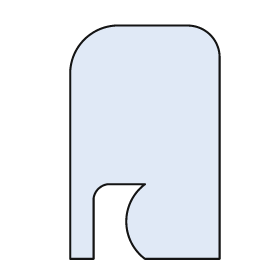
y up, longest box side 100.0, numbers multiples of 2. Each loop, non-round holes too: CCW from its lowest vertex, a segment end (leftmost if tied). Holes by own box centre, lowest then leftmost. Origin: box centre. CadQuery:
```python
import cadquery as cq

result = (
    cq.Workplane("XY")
    .moveTo(-32.0, -50.0)
    .lineTo(-22.0, -50.0)
    .lineTo(-22.0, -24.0)
    .threePointArc((-20.0, -20.0), (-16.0, -18.0))
    .lineTo(0.0, -18.0)
    .threePointArc((-8.0, -34.0), (0.0, -50.0))
    .lineTo(32.0, -50.0)
    .lineTo(32.0, 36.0)
    .threePointArc((28.0, 46.0), (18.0, 50.0))
    .lineTo(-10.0, 50.0)
    .threePointArc((-26.0, 44.0), (-32.0, 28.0))
    .close()
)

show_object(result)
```